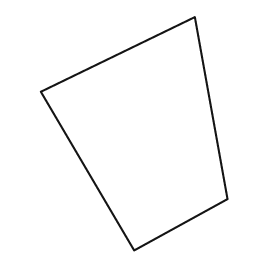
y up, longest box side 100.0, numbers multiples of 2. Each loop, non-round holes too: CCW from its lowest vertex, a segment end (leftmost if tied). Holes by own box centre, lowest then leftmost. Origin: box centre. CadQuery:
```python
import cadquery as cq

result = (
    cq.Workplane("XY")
    .moveTo(0.0, -50.0)
    .lineTo(40.0, -28.0)
    .lineTo(26.0, 50.0)
    .lineTo(-40.0, 18.0)
    .close()
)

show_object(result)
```